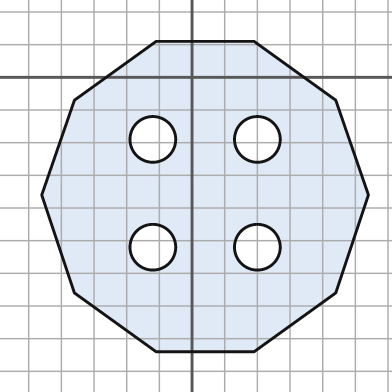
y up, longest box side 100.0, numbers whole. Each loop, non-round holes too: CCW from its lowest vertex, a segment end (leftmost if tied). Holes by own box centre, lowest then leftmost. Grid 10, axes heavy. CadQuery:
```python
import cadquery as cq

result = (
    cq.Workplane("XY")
    .moveTo(-11.0, -84.0)
    .lineTo(19.0, -84.0)
    .lineTo(44.0, -66.0)
    .lineTo(54.0, -36.0)
    .lineTo(44.0, -7.0)
    .lineTo(19.0, 11.0)
    .lineTo(-11.0, 11.0)
    .lineTo(-36.0, -7.0)
    .lineTo(-46.0, -36.0)
    .lineTo(-36.0, -66.0)
    .close()
    .moveTo(-12.0, -52.0)
    .circle(7.0)
    .moveTo(20.0, -52.0)
    .circle(7.0)
    .moveTo(-12.0, -19.0)
    .circle(7.0)
    .moveTo(20.0, -19.0)
    .circle(7.0)
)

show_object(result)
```